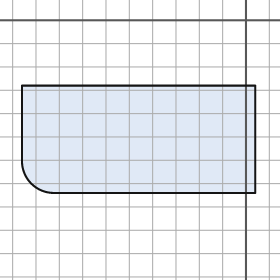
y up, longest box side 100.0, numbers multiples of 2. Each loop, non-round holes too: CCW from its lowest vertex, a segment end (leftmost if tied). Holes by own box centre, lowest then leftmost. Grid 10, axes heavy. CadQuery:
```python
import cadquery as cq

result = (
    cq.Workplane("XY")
    .moveTo(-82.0, -74.0)
    .lineTo(4.0, -74.0)
    .lineTo(4.0, -28.0)
    .lineTo(-96.0, -28.0)
    .lineTo(-96.0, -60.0)
    .threePointArc((-92.0, -70.0), (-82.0, -74.0))
    .close()
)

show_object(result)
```